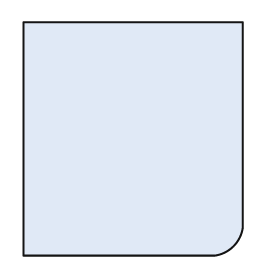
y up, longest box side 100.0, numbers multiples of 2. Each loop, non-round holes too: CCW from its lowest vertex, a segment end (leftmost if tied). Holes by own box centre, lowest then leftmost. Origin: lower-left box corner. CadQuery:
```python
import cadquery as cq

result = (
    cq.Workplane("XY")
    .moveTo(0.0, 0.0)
    .lineTo(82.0, 0.0)
    .threePointArc((90.0, 4.0), (94.0, 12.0))
    .lineTo(94.0, 100.0)
    .lineTo(0.0, 100.0)
    .close()
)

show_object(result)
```